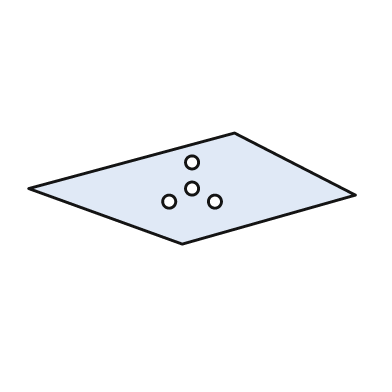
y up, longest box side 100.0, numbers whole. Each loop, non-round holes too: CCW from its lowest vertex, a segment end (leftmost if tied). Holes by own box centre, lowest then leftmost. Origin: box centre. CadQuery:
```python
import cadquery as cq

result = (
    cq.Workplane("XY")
    .moveTo(-3.0, -17.0)
    .lineTo(50.0, -2.0)
    .lineTo(13.0, 17.0)
    .lineTo(-50.0, 0.0)
    .close()
    .moveTo(-7.0, -4.0)
    .circle(2.0)
    .moveTo(7.0, -4.0)
    .circle(2.0)
    .moveTo(0.0, 0.0)
    .circle(2.0)
    .moveTo(0.0, 8.0)
    .circle(2.0)
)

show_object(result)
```